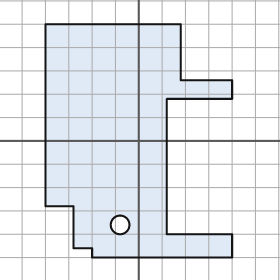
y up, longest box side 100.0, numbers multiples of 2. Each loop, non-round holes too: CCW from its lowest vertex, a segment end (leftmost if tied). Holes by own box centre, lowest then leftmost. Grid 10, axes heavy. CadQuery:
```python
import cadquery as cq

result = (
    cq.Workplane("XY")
    .moveTo(-20.0, -50.0)
    .lineTo(40.0, -50.0)
    .lineTo(40.0, -40.0)
    .lineTo(12.0, -40.0)
    .lineTo(12.0, 18.0)
    .lineTo(40.0, 18.0)
    .lineTo(40.0, 26.0)
    .lineTo(18.0, 26.0)
    .lineTo(18.0, 50.0)
    .lineTo(-40.0, 50.0)
    .lineTo(-40.0, -28.0)
    .lineTo(-28.0, -28.0)
    .lineTo(-28.0, -46.0)
    .lineTo(-20.0, -46.0)
    .close()
    .moveTo(-8.0, -36.0)
    .circle(4.0)
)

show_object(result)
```